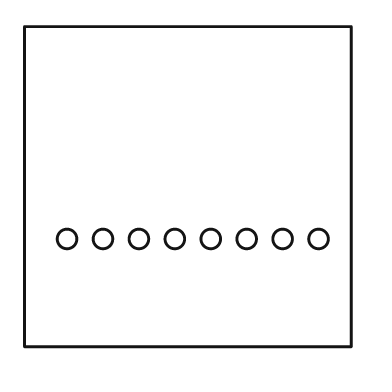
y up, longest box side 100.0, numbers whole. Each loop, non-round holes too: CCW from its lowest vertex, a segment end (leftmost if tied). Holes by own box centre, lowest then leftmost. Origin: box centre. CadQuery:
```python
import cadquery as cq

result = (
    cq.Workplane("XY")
    .moveTo(-50.0, -49.0)
    .lineTo(50.0, -49.0)
    .lineTo(50.0, 49.0)
    .lineTo(-50.0, 49.0)
    .close()
    .moveTo(-37.0, -16.0)
    .circle(3.0)
    .moveTo(-26.0, -16.0)
    .circle(3.0)
    .moveTo(-15.0, -16.0)
    .circle(3.0)
    .moveTo(-4.0, -16.0)
    .circle(3.0)
    .moveTo(7.0, -16.0)
    .circle(3.0)
    .moveTo(18.0, -16.0)
    .circle(3.0)
    .moveTo(29.0, -16.0)
    .circle(3.0)
    .moveTo(40.0, -16.0)
    .circle(3.0)
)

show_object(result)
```